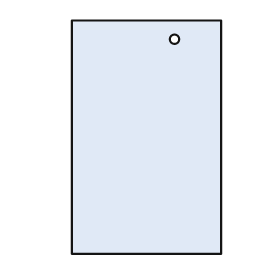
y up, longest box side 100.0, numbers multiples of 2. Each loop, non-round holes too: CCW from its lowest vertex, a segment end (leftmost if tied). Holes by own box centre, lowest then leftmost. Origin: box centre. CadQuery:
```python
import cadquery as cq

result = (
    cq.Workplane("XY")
    .moveTo(-32.0, -50.0)
    .lineTo(32.0, -50.0)
    .lineTo(32.0, 50.0)
    .lineTo(-32.0, 50.0)
    .close()
    .moveTo(12.0, 42.0)
    .circle(2.0)
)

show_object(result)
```